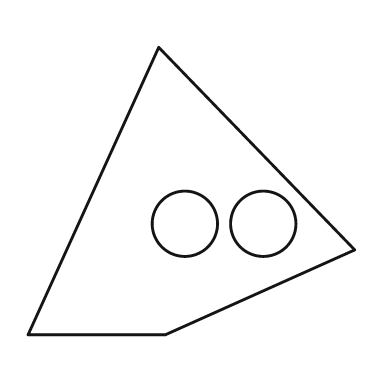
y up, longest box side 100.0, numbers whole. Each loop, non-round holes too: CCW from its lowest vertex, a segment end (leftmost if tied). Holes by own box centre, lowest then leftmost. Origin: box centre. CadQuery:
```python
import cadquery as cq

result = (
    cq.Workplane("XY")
    .moveTo(-50.0, -44.0)
    .lineTo(-8.0, -44.0)
    .lineTo(50.0, -18.0)
    .lineTo(-10.0, 44.0)
    .close()
    .moveTo(-2.0, -10.0)
    .circle(10.0)
    .moveTo(22.0, -10.0)
    .circle(10.0)
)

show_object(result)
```